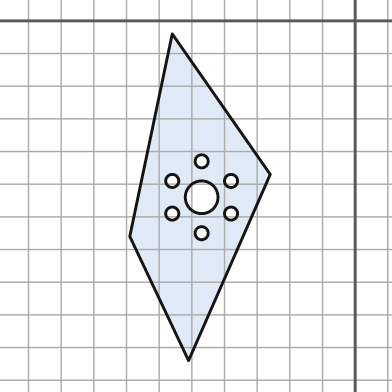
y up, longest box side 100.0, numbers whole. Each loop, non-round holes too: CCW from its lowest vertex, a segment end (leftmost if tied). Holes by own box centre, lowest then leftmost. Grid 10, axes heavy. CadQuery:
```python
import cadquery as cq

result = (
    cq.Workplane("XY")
    .moveTo(-51.0, -104.0)
    .lineTo(-26.0, -47.0)
    .lineTo(-56.0, -4.0)
    .lineTo(-69.0, -66.0)
    .close()
    .moveTo(-47.0, -65.0)
    .circle(2.0)
    .moveTo(-56.0, -59.0)
    .circle(2.0)
    .moveTo(-38.0, -59.0)
    .circle(2.0)
    .moveTo(-47.0, -54.0)
    .circle(5.0)
    .moveTo(-56.0, -49.0)
    .circle(2.0)
    .moveTo(-38.0, -49.0)
    .circle(2.0)
    .moveTo(-47.0, -43.0)
    .circle(2.0)
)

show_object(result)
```